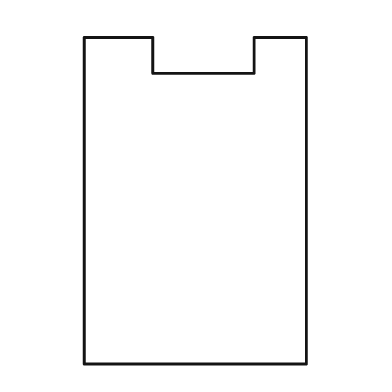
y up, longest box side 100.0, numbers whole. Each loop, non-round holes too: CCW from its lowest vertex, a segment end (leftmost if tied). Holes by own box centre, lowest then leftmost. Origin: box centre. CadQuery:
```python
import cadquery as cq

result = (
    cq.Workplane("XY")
    .moveTo(-34.0, -50.0)
    .lineTo(34.0, -50.0)
    .lineTo(34.0, 50.0)
    .lineTo(18.0, 50.0)
    .lineTo(18.0, 39.0)
    .lineTo(-13.0, 39.0)
    .lineTo(-13.0, 50.0)
    .lineTo(-34.0, 50.0)
    .close()
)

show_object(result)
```